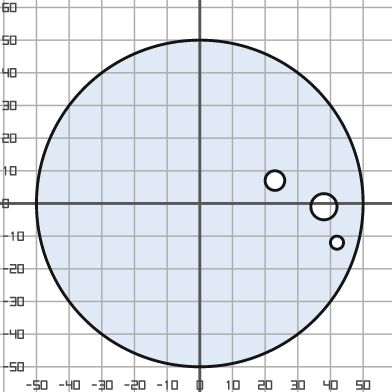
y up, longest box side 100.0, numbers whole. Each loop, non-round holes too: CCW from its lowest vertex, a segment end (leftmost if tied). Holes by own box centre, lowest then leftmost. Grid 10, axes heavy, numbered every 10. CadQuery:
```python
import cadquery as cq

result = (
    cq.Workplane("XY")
    .moveTo(0.0, 0.0)
    .circle(50.0)
    .moveTo(42.0, -12.0)
    .circle(2.0)
    .moveTo(38.0, -1.0)
    .circle(4.0)
    .moveTo(23.0, 7.0)
    .circle(3.0)
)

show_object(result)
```